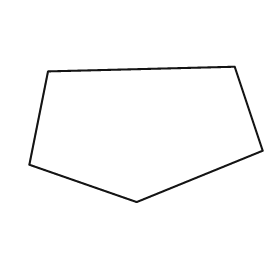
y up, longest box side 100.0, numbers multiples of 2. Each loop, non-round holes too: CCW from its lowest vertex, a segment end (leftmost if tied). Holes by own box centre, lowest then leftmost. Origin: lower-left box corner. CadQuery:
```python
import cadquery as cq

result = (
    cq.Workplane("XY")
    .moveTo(46.0, 0.0)
    .lineTo(100.0, 22.0)
    .lineTo(88.0, 58.0)
    .lineTo(8.0, 56.0)
    .lineTo(0.0, 16.0)
    .close()
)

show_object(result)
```